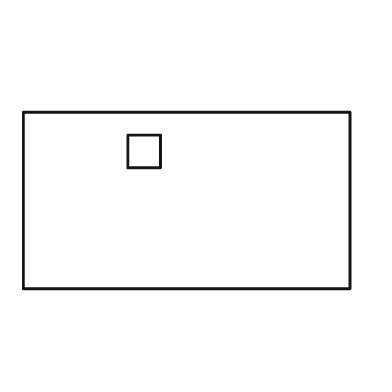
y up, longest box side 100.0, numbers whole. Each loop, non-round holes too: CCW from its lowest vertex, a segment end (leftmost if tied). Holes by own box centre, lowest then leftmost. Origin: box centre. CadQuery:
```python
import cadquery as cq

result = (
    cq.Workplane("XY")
    .moveTo(-50.0, -27.0)
    .lineTo(50.0, -27.0)
    .lineTo(50.0, 27.0)
    .lineTo(-50.0, 27.0)
    .close()
    .moveTo(-18.0, 10.0)
    .lineTo(-8.0, 10.0)
    .lineTo(-8.0, 20.0)
    .lineTo(-18.0, 20.0)
    .close()
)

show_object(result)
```